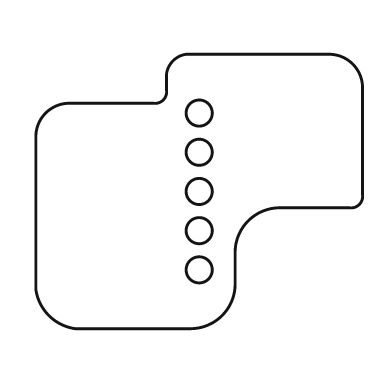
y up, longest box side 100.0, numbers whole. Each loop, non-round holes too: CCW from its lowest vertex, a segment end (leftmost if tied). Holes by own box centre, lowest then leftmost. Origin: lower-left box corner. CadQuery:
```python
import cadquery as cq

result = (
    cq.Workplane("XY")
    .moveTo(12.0, 0.0)
    .lineTo(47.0, 0.0)
    .threePointArc((57.0, 4.0), (61.0, 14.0))
    .lineTo(61.0, 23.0)
    .threePointArc((65.0, 33.0), (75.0, 37.0))
    .lineTo(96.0, 37.0)
    .threePointArc((99.0, 38.0), (100.0, 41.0))
    .lineTo(100.0, 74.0)
    .threePointArc((97.0, 81.0), (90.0, 84.0))
    .lineTo(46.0, 84.0)
    .threePointArc((42.0, 82.0), (40.0, 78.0))
    .lineTo(40.0, 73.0)
    .threePointArc((39.0, 70.0), (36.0, 69.0))
    .lineTo(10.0, 69.0)
    .threePointArc((3.0, 66.0), (0.0, 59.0))
    .lineTo(0.0, 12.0)
    .threePointArc((4.0, 4.0), (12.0, 0.0))
    .close()
    .moveTo(50.0, 18.0)
    .circle(4.0)
    .moveTo(50.0, 30.0)
    .circle(4.0)
    .moveTo(50.0, 42.0)
    .circle(4.0)
    .moveTo(50.0, 54.0)
    .circle(4.0)
    .moveTo(50.0, 66.0)
    .circle(4.0)
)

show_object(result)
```